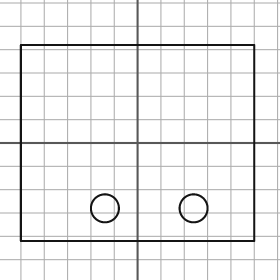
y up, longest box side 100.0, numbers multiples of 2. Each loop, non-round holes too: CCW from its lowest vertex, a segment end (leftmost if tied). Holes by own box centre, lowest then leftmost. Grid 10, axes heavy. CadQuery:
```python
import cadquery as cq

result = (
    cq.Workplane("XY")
    .moveTo(-50.0, -42.0)
    .lineTo(50.0, -42.0)
    .lineTo(50.0, 42.0)
    .lineTo(-50.0, 42.0)
    .close()
    .moveTo(-14.0, -28.0)
    .circle(6.0)
    .moveTo(24.0, -28.0)
    .circle(6.0)
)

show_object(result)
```